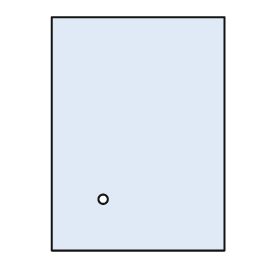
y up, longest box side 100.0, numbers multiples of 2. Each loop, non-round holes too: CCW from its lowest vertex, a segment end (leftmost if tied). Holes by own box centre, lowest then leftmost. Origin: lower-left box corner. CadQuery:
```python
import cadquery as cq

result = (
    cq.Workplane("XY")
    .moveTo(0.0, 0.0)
    .lineTo(74.0, 0.0)
    .lineTo(74.0, 100.0)
    .lineTo(0.0, 100.0)
    .close()
    .moveTo(22.0, 22.0)
    .circle(2.0)
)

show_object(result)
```